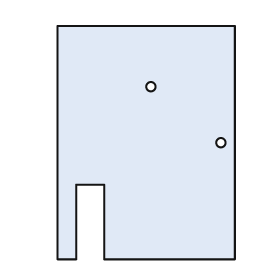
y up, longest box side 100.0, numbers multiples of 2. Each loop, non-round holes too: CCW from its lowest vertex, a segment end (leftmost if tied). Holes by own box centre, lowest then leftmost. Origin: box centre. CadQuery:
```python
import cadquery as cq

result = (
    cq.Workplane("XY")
    .moveTo(-38.0, -50.0)
    .lineTo(-30.0, -50.0)
    .lineTo(-30.0, -18.0)
    .lineTo(-18.0, -18.0)
    .lineTo(-18.0, -50.0)
    .lineTo(38.0, -50.0)
    .lineTo(38.0, 50.0)
    .lineTo(-38.0, 50.0)
    .close()
    .moveTo(32.0, 0.0)
    .circle(2.0)
    .moveTo(2.0, 24.0)
    .circle(2.0)
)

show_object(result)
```